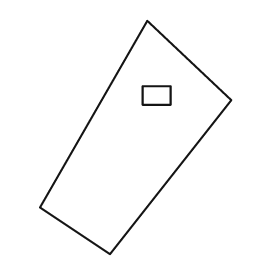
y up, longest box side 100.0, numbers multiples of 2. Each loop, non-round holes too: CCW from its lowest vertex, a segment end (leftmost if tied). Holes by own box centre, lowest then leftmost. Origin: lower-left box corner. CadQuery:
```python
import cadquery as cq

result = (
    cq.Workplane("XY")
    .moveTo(30.0, 0.0)
    .lineTo(82.0, 66.0)
    .lineTo(46.0, 100.0)
    .lineTo(0.0, 20.0)
    .close()
    .moveTo(44.0, 64.0)
    .lineTo(56.0, 64.0)
    .lineTo(56.0, 72.0)
    .lineTo(44.0, 72.0)
    .close()
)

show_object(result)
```